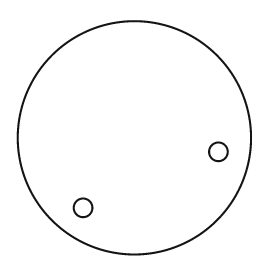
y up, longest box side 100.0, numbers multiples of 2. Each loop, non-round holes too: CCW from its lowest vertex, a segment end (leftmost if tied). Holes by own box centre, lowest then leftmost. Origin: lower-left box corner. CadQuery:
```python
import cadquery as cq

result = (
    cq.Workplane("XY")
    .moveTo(50.0, 50.0)
    .circle(50.0)
    .moveTo(28.0, 20.0)
    .circle(4.0)
    .moveTo(86.0, 44.0)
    .circle(4.0)
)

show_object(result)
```